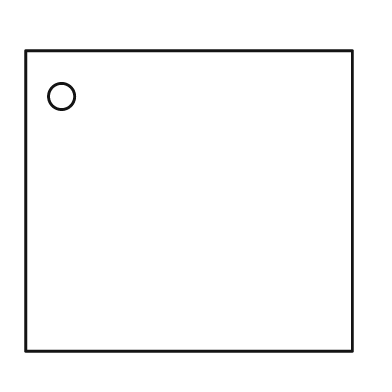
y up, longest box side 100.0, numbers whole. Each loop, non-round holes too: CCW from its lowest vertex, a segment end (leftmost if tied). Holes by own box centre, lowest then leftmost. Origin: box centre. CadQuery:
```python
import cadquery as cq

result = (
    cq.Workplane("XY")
    .moveTo(-50.0, -46.0)
    .lineTo(50.0, -46.0)
    .lineTo(50.0, 46.0)
    .lineTo(-50.0, 46.0)
    .close()
    .moveTo(-39.0, 32.0)
    .circle(4.0)
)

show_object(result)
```